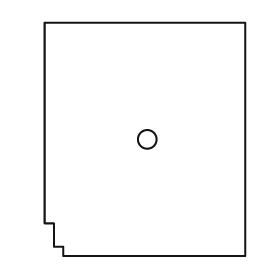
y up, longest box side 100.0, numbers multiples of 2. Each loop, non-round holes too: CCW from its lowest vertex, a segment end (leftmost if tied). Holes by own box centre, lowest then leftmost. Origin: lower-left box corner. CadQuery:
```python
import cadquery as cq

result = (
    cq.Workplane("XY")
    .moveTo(8.0, 0.0)
    .lineTo(86.0, 0.0)
    .lineTo(86.0, 100.0)
    .lineTo(0.0, 100.0)
    .lineTo(0.0, 14.0)
    .lineTo(4.0, 14.0)
    .lineTo(4.0, 4.0)
    .lineTo(8.0, 4.0)
    .close()
    .moveTo(44.0, 50.0)
    .circle(4.0)
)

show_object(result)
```